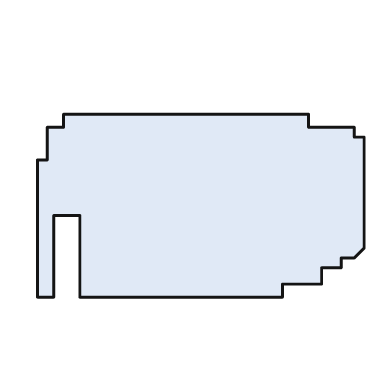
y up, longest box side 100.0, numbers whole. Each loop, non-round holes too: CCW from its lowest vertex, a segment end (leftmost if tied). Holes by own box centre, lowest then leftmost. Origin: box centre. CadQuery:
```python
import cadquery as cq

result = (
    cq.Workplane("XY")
    .moveTo(-50.0, -28.0)
    .lineTo(-45.0, -28.0)
    .lineTo(-45.0, -3.0)
    .lineTo(-37.0, -3.0)
    .lineTo(-37.0, -28.0)
    .lineTo(25.0, -28.0)
    .lineTo(25.0, -24.0)
    .lineTo(37.0, -24.0)
    .lineTo(37.0, -19.0)
    .lineTo(43.0, -19.0)
    .lineTo(43.0, -16.0)
    .lineTo(47.0, -16.0)
    .lineTo(50.0, -13.0)
    .lineTo(50.0, 21.0)
    .lineTo(47.0, 21.0)
    .lineTo(47.0, 24.0)
    .lineTo(33.0, 24.0)
    .lineTo(33.0, 28.0)
    .lineTo(-42.0, 28.0)
    .lineTo(-42.0, 24.0)
    .lineTo(-47.0, 24.0)
    .lineTo(-47.0, 14.0)
    .lineTo(-50.0, 14.0)
    .close()
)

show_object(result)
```